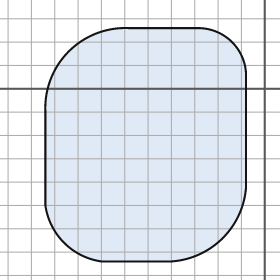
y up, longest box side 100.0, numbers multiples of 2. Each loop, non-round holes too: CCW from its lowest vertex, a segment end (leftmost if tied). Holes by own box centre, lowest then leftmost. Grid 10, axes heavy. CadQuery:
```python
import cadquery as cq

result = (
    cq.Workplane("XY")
    .moveTo(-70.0, -74.0)
    .lineTo(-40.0, -74.0)
    .threePointArc((-18.0, -64.0), (-8.0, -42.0))
    .lineTo(-8.0, 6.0)
    .threePointArc((-14.0, 20.0), (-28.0, 26.0))
    .lineTo(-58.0, 26.0)
    .threePointArc((-84.0, 16.0), (-94.0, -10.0))
    .lineTo(-94.0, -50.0)
    .threePointArc((-86.0, -66.0), (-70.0, -74.0))
    .close()
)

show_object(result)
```